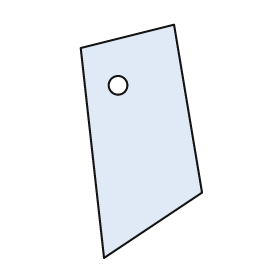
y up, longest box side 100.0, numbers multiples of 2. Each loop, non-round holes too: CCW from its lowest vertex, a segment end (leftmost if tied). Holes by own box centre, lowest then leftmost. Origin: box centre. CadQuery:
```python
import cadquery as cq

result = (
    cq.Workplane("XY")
    .moveTo(-16.0, -50.0)
    .lineTo(26.0, -22.0)
    .lineTo(14.0, 50.0)
    .lineTo(-26.0, 40.0)
    .close()
    .moveTo(-10.0, 24.0)
    .circle(4.0)
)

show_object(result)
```